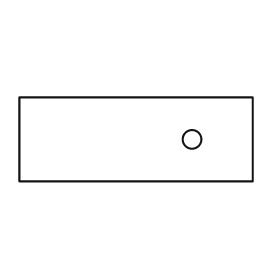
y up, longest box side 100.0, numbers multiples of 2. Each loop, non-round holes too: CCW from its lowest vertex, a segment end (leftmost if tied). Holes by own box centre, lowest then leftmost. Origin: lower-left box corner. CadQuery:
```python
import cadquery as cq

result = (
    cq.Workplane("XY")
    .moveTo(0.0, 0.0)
    .lineTo(100.0, 0.0)
    .lineTo(100.0, 36.0)
    .lineTo(0.0, 36.0)
    .close()
    .moveTo(74.0, 18.0)
    .circle(4.0)
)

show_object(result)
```